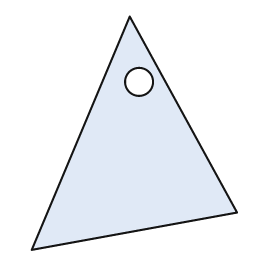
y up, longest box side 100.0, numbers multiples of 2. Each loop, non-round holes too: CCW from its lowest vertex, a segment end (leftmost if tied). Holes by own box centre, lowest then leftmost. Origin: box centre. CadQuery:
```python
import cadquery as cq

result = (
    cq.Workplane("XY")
    .moveTo(-44.0, -50.0)
    .lineTo(44.0, -34.0)
    .lineTo(-2.0, 50.0)
    .close()
    .moveTo(2.0, 22.0)
    .circle(6.0)
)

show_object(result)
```